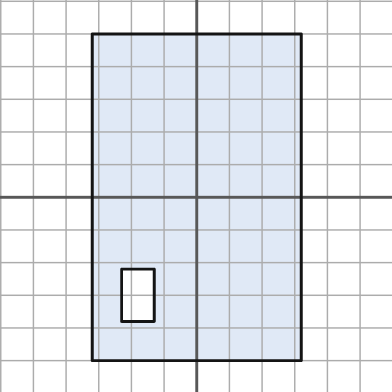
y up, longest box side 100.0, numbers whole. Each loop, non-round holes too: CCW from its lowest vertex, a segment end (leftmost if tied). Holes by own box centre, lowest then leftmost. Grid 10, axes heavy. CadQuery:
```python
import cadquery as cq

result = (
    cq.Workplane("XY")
    .moveTo(-32.0, -50.0)
    .lineTo(32.0, -50.0)
    .lineTo(32.0, 50.0)
    .lineTo(-32.0, 50.0)
    .close()
    .moveTo(-23.0, -38.0)
    .lineTo(-13.0, -38.0)
    .lineTo(-13.0, -22.0)
    .lineTo(-23.0, -22.0)
    .close()
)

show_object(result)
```